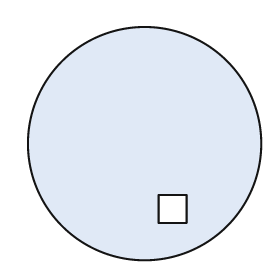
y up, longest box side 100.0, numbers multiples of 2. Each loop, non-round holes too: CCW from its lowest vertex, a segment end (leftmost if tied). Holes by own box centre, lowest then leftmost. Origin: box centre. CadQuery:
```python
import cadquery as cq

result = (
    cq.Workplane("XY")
    .moveTo(0.0, 0.0)
    .circle(50.0)
    .moveTo(6.0, -34.0)
    .lineTo(18.0, -34.0)
    .lineTo(18.0, -22.0)
    .lineTo(6.0, -22.0)
    .close()
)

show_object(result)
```